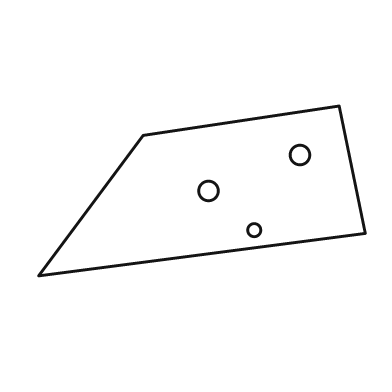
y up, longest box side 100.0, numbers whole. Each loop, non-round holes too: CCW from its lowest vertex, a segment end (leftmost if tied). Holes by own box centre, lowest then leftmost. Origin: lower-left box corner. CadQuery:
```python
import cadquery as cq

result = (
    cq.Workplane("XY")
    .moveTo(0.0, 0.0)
    .lineTo(100.0, 13.0)
    .lineTo(92.0, 52.0)
    .lineTo(32.0, 43.0)
    .close()
    .moveTo(66.0, 14.0)
    .circle(2.0)
    .moveTo(52.0, 26.0)
    .circle(3.0)
    .moveTo(80.0, 37.0)
    .circle(3.0)
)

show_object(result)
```